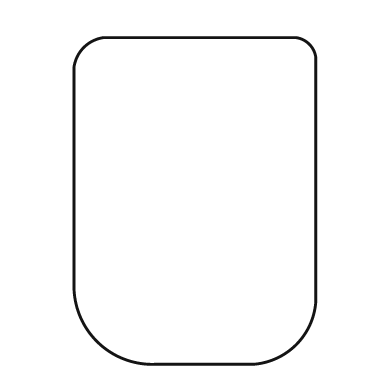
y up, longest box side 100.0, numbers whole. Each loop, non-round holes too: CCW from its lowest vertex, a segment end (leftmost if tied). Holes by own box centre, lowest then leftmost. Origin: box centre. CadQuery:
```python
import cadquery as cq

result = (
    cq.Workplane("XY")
    .moveTo(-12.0, -50.0)
    .lineTo(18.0, -50.0)
    .threePointArc((31.0, -44.0), (37.0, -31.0))
    .lineTo(37.0, 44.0)
    .threePointArc((35.0, 48.0), (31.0, 50.0))
    .lineTo(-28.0, 50.0)
    .threePointArc((-34.0, 47.0), (-37.0, 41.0))
    .lineTo(-37.0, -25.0)
    .threePointArc((-30.0, -43.0), (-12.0, -50.0))
    .close()
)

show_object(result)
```